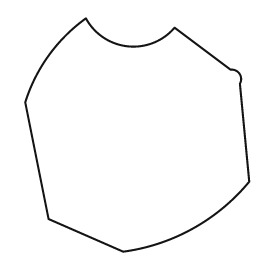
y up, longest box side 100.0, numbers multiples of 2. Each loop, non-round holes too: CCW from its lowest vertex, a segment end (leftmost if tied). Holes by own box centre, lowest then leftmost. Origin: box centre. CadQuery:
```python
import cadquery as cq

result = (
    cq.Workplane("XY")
    .moveTo(-6.0, -50.0)
    .threePointArc((24.0, -40.0), (48.0, -20.0))
    .lineTo(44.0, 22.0)
    .threePointArc((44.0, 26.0), (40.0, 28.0))
    .lineTo(16.0, 46.0)
    .threePointArc((-4.0, 38.0), (-22.0, 50.0))
    .threePointArc((-38.0, 34.0), (-48.0, 14.0))
    .lineTo(-38.0, -36.0)
    .close()
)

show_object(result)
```